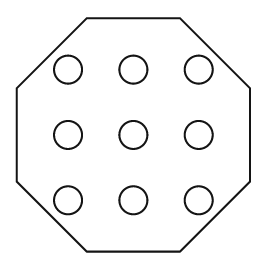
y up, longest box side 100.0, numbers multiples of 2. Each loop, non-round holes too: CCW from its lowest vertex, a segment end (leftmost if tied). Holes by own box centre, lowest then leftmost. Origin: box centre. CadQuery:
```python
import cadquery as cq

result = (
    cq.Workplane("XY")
    .moveTo(-20.0, -50.0)
    .lineTo(20.0, -50.0)
    .lineTo(50.0, -20.0)
    .lineTo(50.0, 20.0)
    .lineTo(20.0, 50.0)
    .lineTo(-20.0, 50.0)
    .lineTo(-50.0, 20.0)
    .lineTo(-50.0, -20.0)
    .close()
    .moveTo(-28.0, -28.0)
    .circle(6.0)
    .moveTo(0.0, -28.0)
    .circle(6.0)
    .moveTo(28.0, -28.0)
    .circle(6.0)
    .moveTo(-28.0, 0.0)
    .circle(6.0)
    .moveTo(0.0, 0.0)
    .circle(6.0)
    .moveTo(28.0, 0.0)
    .circle(6.0)
    .moveTo(-28.0, 28.0)
    .circle(6.0)
    .moveTo(0.0, 28.0)
    .circle(6.0)
    .moveTo(28.0, 28.0)
    .circle(6.0)
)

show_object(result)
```